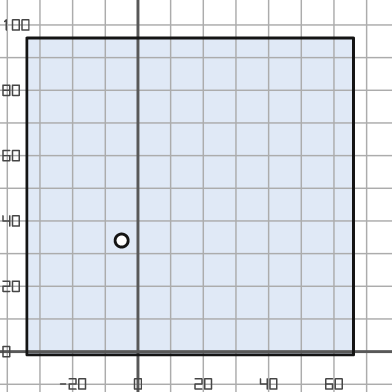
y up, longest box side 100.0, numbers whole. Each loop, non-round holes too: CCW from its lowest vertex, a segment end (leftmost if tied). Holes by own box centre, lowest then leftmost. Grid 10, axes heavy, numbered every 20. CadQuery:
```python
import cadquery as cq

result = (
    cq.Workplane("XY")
    .moveTo(-34.0, -1.0)
    .lineTo(66.0, -1.0)
    .lineTo(66.0, 96.0)
    .lineTo(-34.0, 96.0)
    .close()
    .moveTo(-5.0, 34.0)
    .circle(2.0)
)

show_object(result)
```